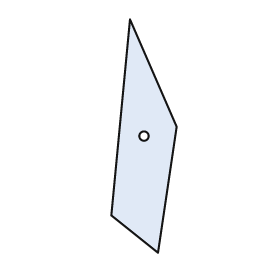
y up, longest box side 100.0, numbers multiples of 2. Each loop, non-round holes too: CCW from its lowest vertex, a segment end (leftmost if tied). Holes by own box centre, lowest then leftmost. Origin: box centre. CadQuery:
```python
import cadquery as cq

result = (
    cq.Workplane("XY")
    .moveTo(6.0, -50.0)
    .lineTo(14.0, 4.0)
    .lineTo(-6.0, 50.0)
    .lineTo(-14.0, -34.0)
    .close()
    .moveTo(0.0, 0.0)
    .circle(2.0)
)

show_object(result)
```